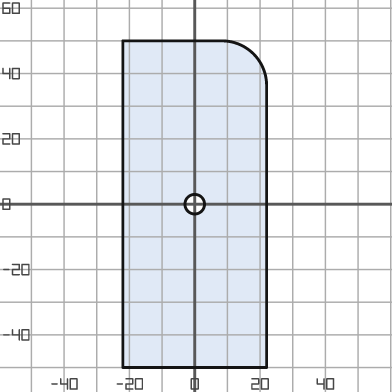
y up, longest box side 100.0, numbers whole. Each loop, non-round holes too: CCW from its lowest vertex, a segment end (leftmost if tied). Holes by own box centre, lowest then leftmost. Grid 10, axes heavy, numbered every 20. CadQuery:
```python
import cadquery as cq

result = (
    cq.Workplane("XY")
    .moveTo(-22.0, -50.0)
    .lineTo(22.0, -50.0)
    .lineTo(22.0, 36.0)
    .threePointArc((18.0, 46.0), (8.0, 50.0))
    .lineTo(-22.0, 50.0)
    .close()
    .moveTo(0.0, 0.0)
    .circle(3.0)
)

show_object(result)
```